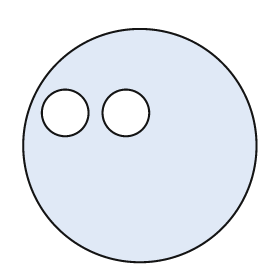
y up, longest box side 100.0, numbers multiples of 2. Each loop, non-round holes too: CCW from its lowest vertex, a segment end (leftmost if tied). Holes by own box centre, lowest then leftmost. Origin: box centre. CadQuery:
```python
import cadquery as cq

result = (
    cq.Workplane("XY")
    .moveTo(0.0, 0.0)
    .circle(50.0)
    .moveTo(-32.0, 14.0)
    .circle(10.0)
    .moveTo(-6.0, 14.0)
    .circle(10.0)
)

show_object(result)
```